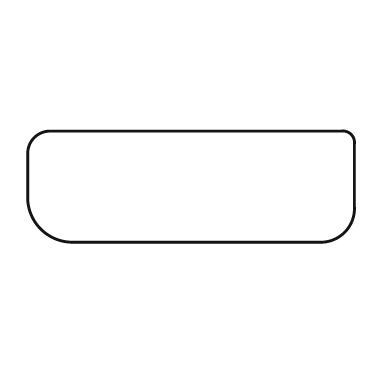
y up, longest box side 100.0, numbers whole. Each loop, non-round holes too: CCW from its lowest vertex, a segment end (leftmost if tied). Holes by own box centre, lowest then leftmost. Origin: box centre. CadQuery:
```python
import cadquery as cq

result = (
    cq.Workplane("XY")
    .moveTo(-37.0, -17.0)
    .lineTo(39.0, -17.0)
    .threePointArc((47.0, -14.0), (50.0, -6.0))
    .lineTo(50.0, 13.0)
    .threePointArc((49.0, 16.0), (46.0, 17.0))
    .lineTo(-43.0, 17.0)
    .threePointArc((-48.0, 15.0), (-50.0, 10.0))
    .lineTo(-50.0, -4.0)
    .threePointArc((-46.0, -13.0), (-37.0, -17.0))
    .close()
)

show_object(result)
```